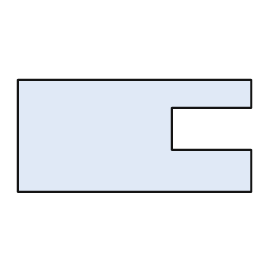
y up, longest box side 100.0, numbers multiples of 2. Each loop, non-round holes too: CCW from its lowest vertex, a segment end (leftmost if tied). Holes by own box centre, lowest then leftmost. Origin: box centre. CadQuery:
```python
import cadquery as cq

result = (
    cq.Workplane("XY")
    .moveTo(-50.0, -24.0)
    .lineTo(50.0, -24.0)
    .lineTo(50.0, -6.0)
    .lineTo(16.0, -6.0)
    .lineTo(16.0, 12.0)
    .lineTo(50.0, 12.0)
    .lineTo(50.0, 24.0)
    .lineTo(-50.0, 24.0)
    .close()
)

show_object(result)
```